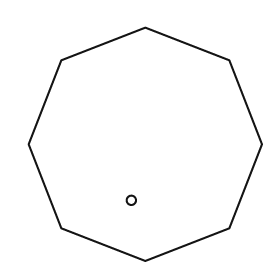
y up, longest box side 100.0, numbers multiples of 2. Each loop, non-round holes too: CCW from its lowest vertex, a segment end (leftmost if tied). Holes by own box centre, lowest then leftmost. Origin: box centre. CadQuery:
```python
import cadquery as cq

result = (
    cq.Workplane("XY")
    .moveTo(0.0, -50.0)
    .lineTo(36.0, -36.0)
    .lineTo(50.0, 0.0)
    .lineTo(36.0, 36.0)
    .lineTo(0.0, 50.0)
    .lineTo(-36.0, 36.0)
    .lineTo(-50.0, 0.0)
    .lineTo(-36.0, -36.0)
    .close()
    .moveTo(-6.0, -24.0)
    .circle(2.0)
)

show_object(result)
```